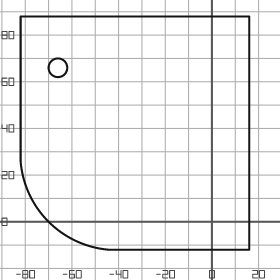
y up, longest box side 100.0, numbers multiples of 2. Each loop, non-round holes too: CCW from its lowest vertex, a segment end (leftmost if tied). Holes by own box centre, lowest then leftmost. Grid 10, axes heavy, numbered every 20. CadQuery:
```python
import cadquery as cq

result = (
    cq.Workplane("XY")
    .moveTo(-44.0, -12.0)
    .lineTo(16.0, -12.0)
    .lineTo(16.0, 88.0)
    .lineTo(-82.0, 88.0)
    .lineTo(-82.0, 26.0)
    .threePointArc((-70.0, 0.0), (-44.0, -12.0))
    .close()
    .moveTo(-66.0, 66.0)
    .circle(4.0)
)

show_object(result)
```